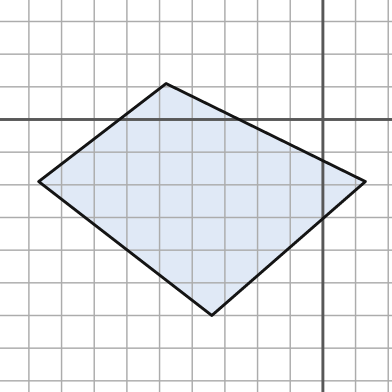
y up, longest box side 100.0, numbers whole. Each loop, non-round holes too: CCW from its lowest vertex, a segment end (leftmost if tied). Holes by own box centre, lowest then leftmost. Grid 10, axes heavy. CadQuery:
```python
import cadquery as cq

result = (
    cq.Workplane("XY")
    .moveTo(-34.0, -60.0)
    .lineTo(13.0, -19.0)
    .lineTo(-48.0, 11.0)
    .lineTo(-87.0, -19.0)
    .close()
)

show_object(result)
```